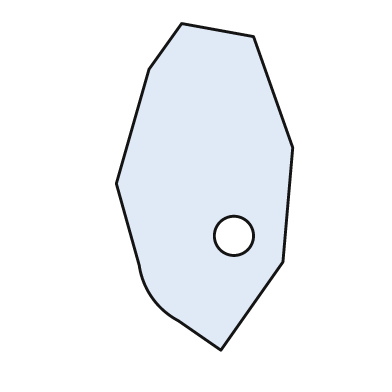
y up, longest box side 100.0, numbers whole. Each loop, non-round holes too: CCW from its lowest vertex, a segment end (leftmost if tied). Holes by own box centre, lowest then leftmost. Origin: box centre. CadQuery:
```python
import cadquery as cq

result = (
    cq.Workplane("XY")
    .moveTo(5.0, -50.0)
    .lineTo(24.0, -23.0)
    .lineTo(27.0, 12.0)
    .lineTo(15.0, 46.0)
    .lineTo(-7.0, 50.0)
    .lineTo(-17.0, 36.0)
    .lineTo(-27.0, 1.0)
    .lineTo(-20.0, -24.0)
    .threePointArc((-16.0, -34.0), (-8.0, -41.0))
    .close()
    .moveTo(9.0, -15.0)
    .circle(6.0)
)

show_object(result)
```